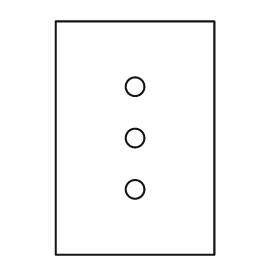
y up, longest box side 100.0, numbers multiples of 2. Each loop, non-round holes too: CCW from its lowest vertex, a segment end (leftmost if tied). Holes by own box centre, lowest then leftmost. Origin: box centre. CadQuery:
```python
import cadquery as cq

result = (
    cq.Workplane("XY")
    .moveTo(-34.0, -50.0)
    .lineTo(34.0, -50.0)
    .lineTo(34.0, 50.0)
    .lineTo(-34.0, 50.0)
    .close()
    .moveTo(0.0, -22.0)
    .circle(4.0)
    .moveTo(0.0, 0.0)
    .circle(4.0)
    .moveTo(0.0, 22.0)
    .circle(4.0)
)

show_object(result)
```